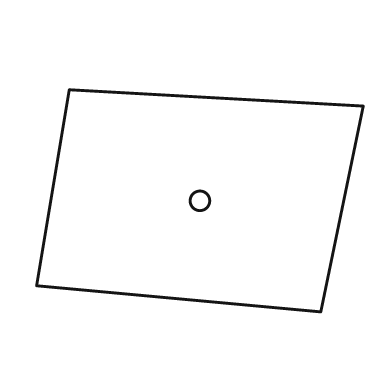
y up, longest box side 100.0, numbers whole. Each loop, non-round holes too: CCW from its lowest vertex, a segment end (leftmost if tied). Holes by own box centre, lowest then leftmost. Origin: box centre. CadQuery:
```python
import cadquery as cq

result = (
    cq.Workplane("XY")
    .moveTo(37.0, -34.0)
    .lineTo(50.0, 29.0)
    .lineTo(-40.0, 34.0)
    .lineTo(-50.0, -26.0)
    .close()
    .moveTo(0.0, 0.0)
    .circle(3.0)
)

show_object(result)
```